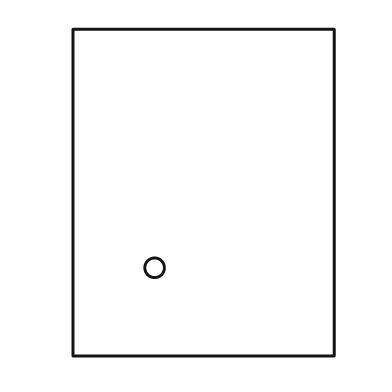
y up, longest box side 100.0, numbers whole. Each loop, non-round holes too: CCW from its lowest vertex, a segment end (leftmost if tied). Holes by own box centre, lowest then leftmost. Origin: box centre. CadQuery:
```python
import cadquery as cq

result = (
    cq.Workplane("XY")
    .moveTo(-40.0, -50.0)
    .lineTo(40.0, -50.0)
    .lineTo(40.0, 50.0)
    .lineTo(-40.0, 50.0)
    .close()
    .moveTo(-15.0, -23.0)
    .circle(3.0)
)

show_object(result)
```